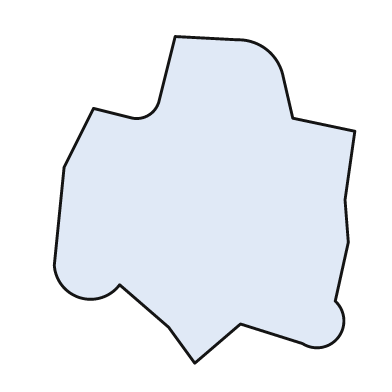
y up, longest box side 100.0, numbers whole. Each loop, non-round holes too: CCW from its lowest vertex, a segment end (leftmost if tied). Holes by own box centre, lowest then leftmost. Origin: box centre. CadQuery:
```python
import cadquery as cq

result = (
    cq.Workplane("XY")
    .moveTo(-3.0, -50.0)
    .lineTo(11.0, -38.0)
    .lineTo(30.0, -44.0)
    .threePointArc((41.0, -42.0), (40.0, -31.0))
    .lineTo(44.0, -13.0)
    .lineTo(43.0, 0.0)
    .lineTo(46.0, 21.0)
    .lineTo(27.0, 25.0)
    .lineTo(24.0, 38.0)
    .threePointArc((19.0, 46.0), (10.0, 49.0))
    .lineTo(-9.0, 50.0)
    .lineTo(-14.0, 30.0)
    .threePointArc((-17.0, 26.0), (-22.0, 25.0))
    .lineTo(-34.0, 28.0)
    .lineTo(-43.0, 10.0)
    .lineTo(-46.0, -20.0)
    .threePointArc((-38.0, -30.0), (-26.0, -26.0))
    .lineTo(-11.0, -39.0)
    .close()
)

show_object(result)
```